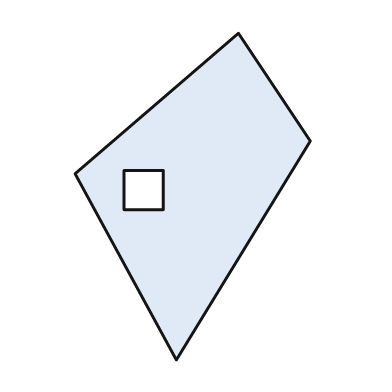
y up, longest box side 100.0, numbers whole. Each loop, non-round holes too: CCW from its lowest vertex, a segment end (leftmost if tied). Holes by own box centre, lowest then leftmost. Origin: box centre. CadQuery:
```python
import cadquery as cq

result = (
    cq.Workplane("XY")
    .moveTo(-5.0, -50.0)
    .lineTo(36.0, 17.0)
    .lineTo(14.0, 50.0)
    .lineTo(-36.0, 7.0)
    .close()
    .moveTo(-21.0, -4.0)
    .lineTo(-9.0, -4.0)
    .lineTo(-9.0, 8.0)
    .lineTo(-21.0, 8.0)
    .close()
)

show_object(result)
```